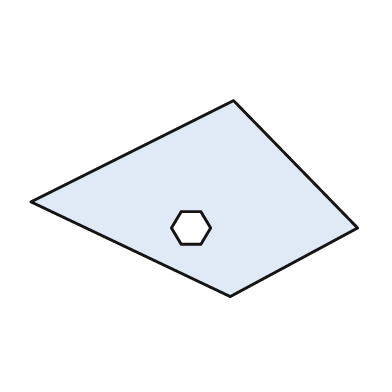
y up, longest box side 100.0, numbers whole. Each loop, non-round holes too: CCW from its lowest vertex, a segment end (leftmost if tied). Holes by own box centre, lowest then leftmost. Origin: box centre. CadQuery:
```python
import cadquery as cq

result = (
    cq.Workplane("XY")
    .moveTo(11.0, -30.0)
    .lineTo(50.0, -9.0)
    .lineTo(12.0, 30.0)
    .lineTo(-50.0, -1.0)
    .close()
    .moveTo(-4.0, -14.0)
    .lineTo(2.0, -14.0)
    .lineTo(5.0, -9.0)
    .lineTo(2.0, -4.0)
    .lineTo(-4.0, -4.0)
    .lineTo(-7.0, -9.0)
    .close()
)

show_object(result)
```